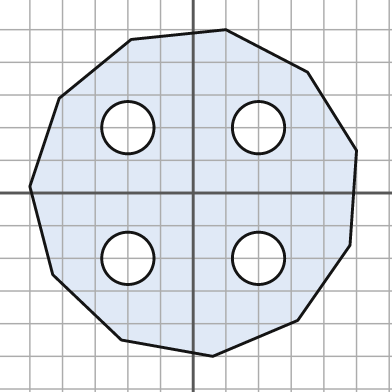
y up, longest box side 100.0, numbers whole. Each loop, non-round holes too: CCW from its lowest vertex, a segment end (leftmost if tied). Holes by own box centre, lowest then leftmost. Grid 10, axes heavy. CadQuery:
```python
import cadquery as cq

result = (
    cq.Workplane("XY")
    .moveTo(6.0, -50.0)
    .lineTo(32.0, -39.0)
    .lineTo(48.0, -16.0)
    .lineTo(50.0, 13.0)
    .lineTo(35.0, 37.0)
    .lineTo(10.0, 50.0)
    .lineTo(-19.0, 47.0)
    .lineTo(-41.0, 29.0)
    .lineTo(-50.0, 2.0)
    .lineTo(-43.0, -25.0)
    .lineTo(-22.0, -45.0)
    .close()
    .moveTo(-20.0, -20.0)
    .circle(8.0)
    .moveTo(20.0, -20.0)
    .circle(8.0)
    .moveTo(-20.0, 20.0)
    .circle(8.0)
    .moveTo(20.0, 20.0)
    .circle(8.0)
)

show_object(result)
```